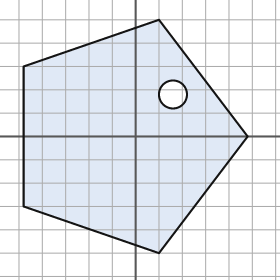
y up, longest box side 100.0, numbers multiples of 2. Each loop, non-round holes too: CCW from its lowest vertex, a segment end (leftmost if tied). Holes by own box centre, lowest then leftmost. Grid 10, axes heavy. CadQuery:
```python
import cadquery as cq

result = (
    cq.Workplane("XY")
    .moveTo(10.0, -50.0)
    .lineTo(48.0, 0.0)
    .lineTo(10.0, 50.0)
    .lineTo(-48.0, 30.0)
    .lineTo(-48.0, -30.0)
    .close()
    .moveTo(16.0, 18.0)
    .circle(6.0)
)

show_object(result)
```